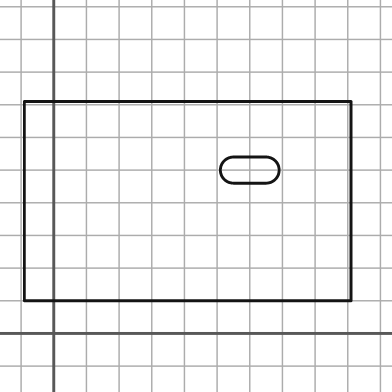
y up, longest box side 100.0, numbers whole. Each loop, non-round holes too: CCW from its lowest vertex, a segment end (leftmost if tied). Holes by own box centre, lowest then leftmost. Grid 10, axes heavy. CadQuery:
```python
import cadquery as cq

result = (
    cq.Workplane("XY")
    .moveTo(-9.0, 10.0)
    .lineTo(91.0, 10.0)
    .lineTo(91.0, 71.0)
    .lineTo(-9.0, 71.0)
    .close()
    .moveTo(55.0, 46.0)
    .lineTo(65.0, 46.0)
    .threePointArc((69.0, 50.0), (65.0, 54.0))
    .lineTo(55.0, 54.0)
    .threePointArc((51.0, 50.0), (55.0, 46.0))
    .close()
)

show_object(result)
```